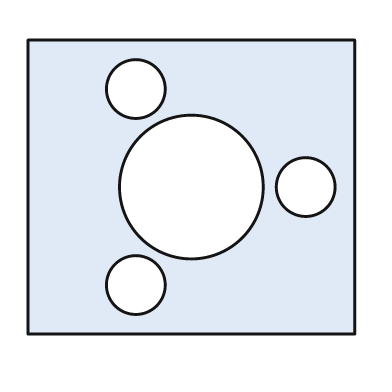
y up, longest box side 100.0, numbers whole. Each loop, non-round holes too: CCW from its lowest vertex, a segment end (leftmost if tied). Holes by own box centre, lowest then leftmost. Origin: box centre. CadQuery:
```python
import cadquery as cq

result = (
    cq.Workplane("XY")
    .moveTo(-50.0, -45.0)
    .lineTo(50.0, -45.0)
    .lineTo(50.0, 45.0)
    .lineTo(-50.0, 45.0)
    .close()
    .moveTo(-17.0, -30.0)
    .circle(9.0)
    .moveTo(0.0, 0.0)
    .circle(22.0)
    .moveTo(35.0, 0.0)
    .circle(9.0)
    .moveTo(-17.0, 30.0)
    .circle(9.0)
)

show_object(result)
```